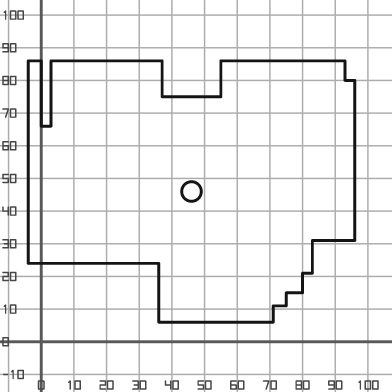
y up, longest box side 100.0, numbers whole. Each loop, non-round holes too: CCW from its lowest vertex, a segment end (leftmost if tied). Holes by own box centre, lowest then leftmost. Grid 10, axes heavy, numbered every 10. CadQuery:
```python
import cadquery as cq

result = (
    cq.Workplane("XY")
    .moveTo(36.0, 6.0)
    .lineTo(71.0, 6.0)
    .lineTo(71.0, 11.0)
    .lineTo(75.0, 11.0)
    .lineTo(75.0, 15.0)
    .lineTo(80.0, 15.0)
    .lineTo(80.0, 21.0)
    .lineTo(83.0, 21.0)
    .lineTo(83.0, 31.0)
    .lineTo(96.0, 31.0)
    .lineTo(96.0, 80.0)
    .lineTo(93.0, 80.0)
    .lineTo(93.0, 86.0)
    .lineTo(55.0, 86.0)
    .lineTo(55.0, 75.0)
    .lineTo(37.0, 75.0)
    .lineTo(37.0, 86.0)
    .lineTo(3.0, 86.0)
    .lineTo(3.0, 66.0)
    .lineTo(0.0, 66.0)
    .lineTo(0.0, 86.0)
    .lineTo(-4.0, 86.0)
    .lineTo(-4.0, 24.0)
    .lineTo(36.0, 24.0)
    .close()
    .moveTo(46.0, 46.0)
    .circle(3.0)
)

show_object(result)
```